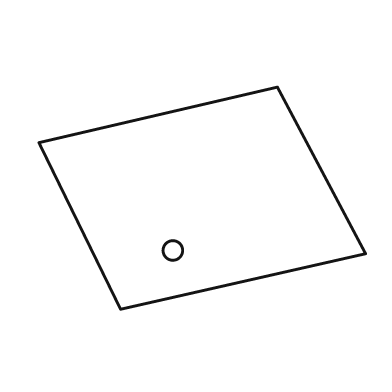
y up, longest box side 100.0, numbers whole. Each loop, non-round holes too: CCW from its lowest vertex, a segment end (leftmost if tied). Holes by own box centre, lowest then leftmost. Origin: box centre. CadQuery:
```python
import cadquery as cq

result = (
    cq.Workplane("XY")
    .moveTo(-25.0, -34.0)
    .lineTo(50.0, -17.0)
    .lineTo(23.0, 34.0)
    .lineTo(-50.0, 17.0)
    .close()
    .moveTo(-9.0, -16.0)
    .circle(3.0)
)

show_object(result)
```